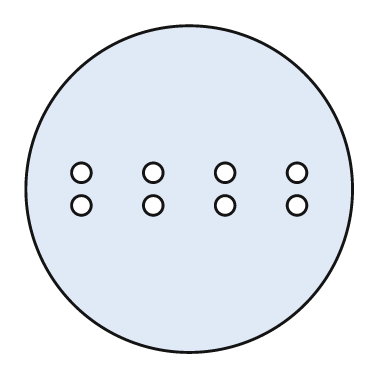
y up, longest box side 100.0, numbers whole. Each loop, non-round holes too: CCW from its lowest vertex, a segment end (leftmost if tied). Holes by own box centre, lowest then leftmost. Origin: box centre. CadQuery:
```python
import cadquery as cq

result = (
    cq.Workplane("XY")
    .moveTo(0.0, 0.0)
    .circle(50.0)
    .moveTo(-33.0, -5.0)
    .circle(3.0)
    .moveTo(-11.0, -5.0)
    .circle(3.0)
    .moveTo(11.0, -5.0)
    .circle(3.0)
    .moveTo(33.0, -5.0)
    .circle(3.0)
    .moveTo(-33.0, 5.0)
    .circle(3.0)
    .moveTo(-11.0, 5.0)
    .circle(3.0)
    .moveTo(11.0, 5.0)
    .circle(3.0)
    .moveTo(33.0, 5.0)
    .circle(3.0)
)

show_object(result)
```